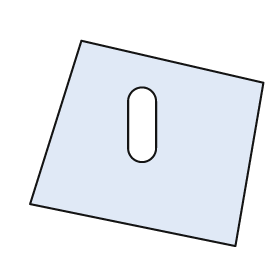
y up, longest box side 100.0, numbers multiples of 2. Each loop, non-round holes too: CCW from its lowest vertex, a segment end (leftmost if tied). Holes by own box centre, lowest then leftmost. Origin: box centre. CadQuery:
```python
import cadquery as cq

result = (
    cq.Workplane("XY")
    .moveTo(38.0, -44.0)
    .lineTo(50.0, 26.0)
    .lineTo(-28.0, 44.0)
    .lineTo(-50.0, -26.0)
    .close()
    .moveTo(-8.0, -2.0)
    .threePointArc((-2.0, -8.0), (4.0, -2.0))
    .lineTo(4.0, 18.0)
    .threePointArc((-2.0, 24.0), (-8.0, 18.0))
    .close()
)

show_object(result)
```